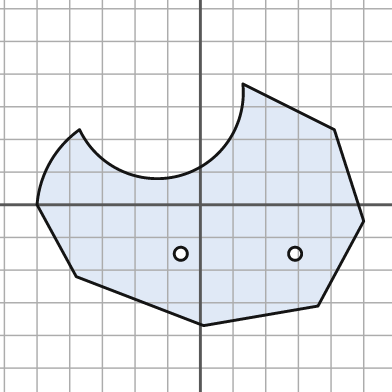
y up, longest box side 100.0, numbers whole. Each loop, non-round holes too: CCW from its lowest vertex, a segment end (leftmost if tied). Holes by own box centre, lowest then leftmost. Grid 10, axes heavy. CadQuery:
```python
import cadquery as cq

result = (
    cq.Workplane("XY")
    .moveTo(1.0, -37.0)
    .lineTo(36.0, -31.0)
    .lineTo(50.0, -5.0)
    .lineTo(41.0, 23.0)
    .lineTo(13.0, 37.0)
    .threePointArc((-6.0, 9.0), (-37.0, 23.0))
    .threePointArc((-46.0, 13.0), (-50.0, 0.0))
    .lineTo(-38.0, -22.0)
    .close()
    .moveTo(-6.0, -15.0)
    .circle(2.0)
    .moveTo(29.0, -15.0)
    .circle(2.0)
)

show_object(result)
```